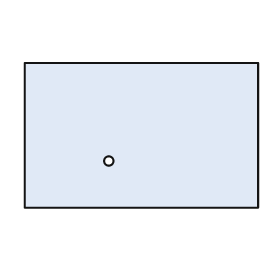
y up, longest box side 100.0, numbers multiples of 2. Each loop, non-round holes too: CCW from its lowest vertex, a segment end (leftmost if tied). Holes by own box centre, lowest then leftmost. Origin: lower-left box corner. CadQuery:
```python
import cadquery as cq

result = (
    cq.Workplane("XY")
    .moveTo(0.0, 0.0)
    .lineTo(100.0, 0.0)
    .lineTo(100.0, 62.0)
    .lineTo(0.0, 62.0)
    .close()
    .moveTo(36.0, 20.0)
    .circle(2.0)
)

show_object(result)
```